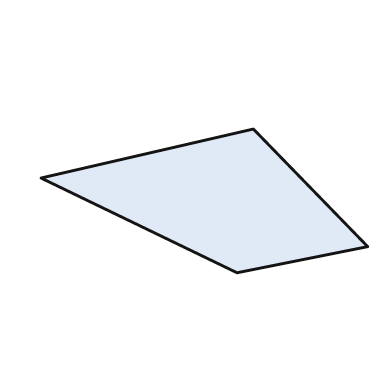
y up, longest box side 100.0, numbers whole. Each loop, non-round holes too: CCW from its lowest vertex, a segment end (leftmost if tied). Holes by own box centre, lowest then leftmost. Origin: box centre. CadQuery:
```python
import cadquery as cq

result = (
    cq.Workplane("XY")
    .moveTo(10.0, -22.0)
    .lineTo(50.0, -14.0)
    .lineTo(15.0, 22.0)
    .lineTo(-50.0, 7.0)
    .close()
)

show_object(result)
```